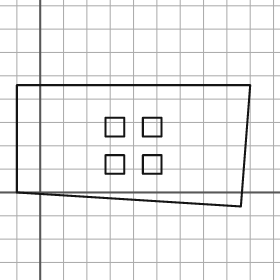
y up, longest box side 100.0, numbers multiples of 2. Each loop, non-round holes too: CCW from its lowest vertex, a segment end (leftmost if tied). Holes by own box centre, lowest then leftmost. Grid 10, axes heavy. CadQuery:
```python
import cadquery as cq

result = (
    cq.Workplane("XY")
    .moveTo(86.0, -6.0)
    .lineTo(90.0, 46.0)
    .lineTo(-10.0, 46.0)
    .lineTo(-10.0, 0.0)
    .close()
    .moveTo(28.0, 8.0)
    .lineTo(36.0, 8.0)
    .lineTo(36.0, 16.0)
    .lineTo(28.0, 16.0)
    .close()
    .moveTo(44.0, 8.0)
    .lineTo(52.0, 8.0)
    .lineTo(52.0, 16.0)
    .lineTo(44.0, 16.0)
    .close()
    .moveTo(28.0, 24.0)
    .lineTo(36.0, 24.0)
    .lineTo(36.0, 32.0)
    .lineTo(28.0, 32.0)
    .close()
    .moveTo(44.0, 24.0)
    .lineTo(52.0, 24.0)
    .lineTo(52.0, 32.0)
    .lineTo(44.0, 32.0)
    .close()
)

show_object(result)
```